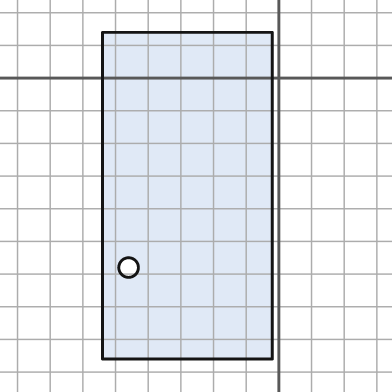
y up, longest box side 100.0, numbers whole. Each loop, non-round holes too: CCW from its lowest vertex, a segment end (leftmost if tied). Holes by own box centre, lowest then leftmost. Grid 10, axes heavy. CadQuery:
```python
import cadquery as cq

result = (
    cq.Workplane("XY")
    .moveTo(-54.0, -86.0)
    .lineTo(-2.0, -86.0)
    .lineTo(-2.0, 14.0)
    .lineTo(-54.0, 14.0)
    .close()
    .moveTo(-46.0, -58.0)
    .circle(3.0)
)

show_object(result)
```